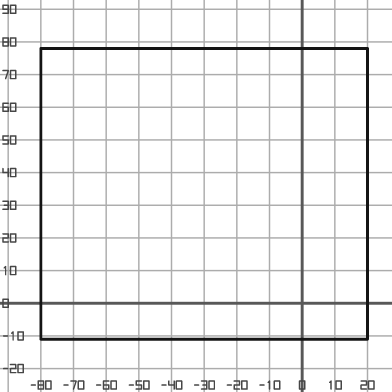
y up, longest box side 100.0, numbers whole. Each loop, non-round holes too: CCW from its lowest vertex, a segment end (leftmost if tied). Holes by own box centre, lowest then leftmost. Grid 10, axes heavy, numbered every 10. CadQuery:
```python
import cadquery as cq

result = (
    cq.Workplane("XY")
    .moveTo(-80.0, -11.0)
    .lineTo(20.0, -11.0)
    .lineTo(20.0, 78.0)
    .lineTo(-80.0, 78.0)
    .close()
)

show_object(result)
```